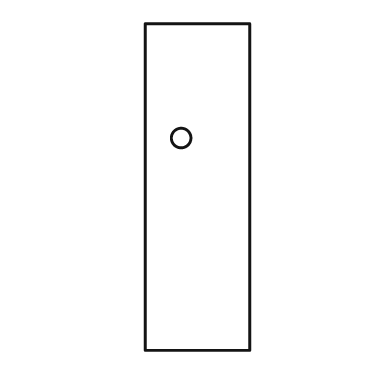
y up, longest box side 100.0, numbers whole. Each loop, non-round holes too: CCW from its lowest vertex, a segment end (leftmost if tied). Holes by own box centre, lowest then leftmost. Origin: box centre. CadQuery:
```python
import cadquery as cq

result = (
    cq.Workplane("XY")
    .moveTo(-16.0, -50.0)
    .lineTo(16.0, -50.0)
    .lineTo(16.0, 50.0)
    .lineTo(-16.0, 50.0)
    .close()
    .moveTo(-5.0, 15.0)
    .circle(3.0)
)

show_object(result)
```